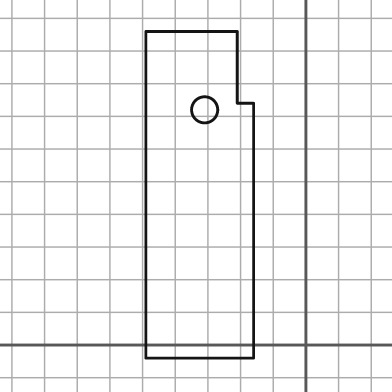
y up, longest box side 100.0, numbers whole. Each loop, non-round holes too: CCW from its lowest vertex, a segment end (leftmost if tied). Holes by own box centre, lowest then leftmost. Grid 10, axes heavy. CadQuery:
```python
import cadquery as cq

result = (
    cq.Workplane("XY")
    .moveTo(-49.0, -4.0)
    .lineTo(-16.0, -4.0)
    .lineTo(-16.0, 74.0)
    .lineTo(-21.0, 74.0)
    .lineTo(-21.0, 96.0)
    .lineTo(-49.0, 96.0)
    .close()
    .moveTo(-31.0, 72.0)
    .circle(4.0)
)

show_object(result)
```